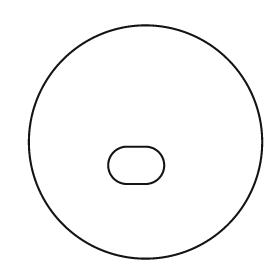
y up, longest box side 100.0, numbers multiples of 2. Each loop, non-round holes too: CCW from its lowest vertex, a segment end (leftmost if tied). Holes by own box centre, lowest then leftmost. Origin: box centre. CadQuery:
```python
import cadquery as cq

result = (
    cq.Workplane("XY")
    .moveTo(0.0, 0.0)
    .circle(50.0)
    .moveTo(-8.0, -18.0)
    .lineTo(0.0, -18.0)
    .threePointArc((8.0, -10.0), (0.0, -2.0))
    .lineTo(-8.0, -2.0)
    .threePointArc((-16.0, -10.0), (-8.0, -18.0))
    .close()
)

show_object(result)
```